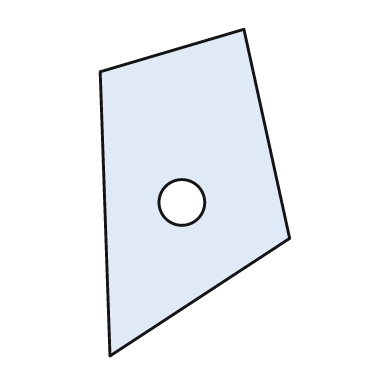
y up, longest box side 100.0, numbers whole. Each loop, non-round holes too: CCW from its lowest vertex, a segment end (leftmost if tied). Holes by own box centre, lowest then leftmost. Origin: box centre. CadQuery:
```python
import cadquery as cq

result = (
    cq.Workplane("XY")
    .moveTo(-26.0, -50.0)
    .lineTo(29.0, -14.0)
    .lineTo(15.0, 50.0)
    .lineTo(-29.0, 37.0)
    .close()
    .moveTo(-4.0, -3.0)
    .circle(7.0)
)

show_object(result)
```